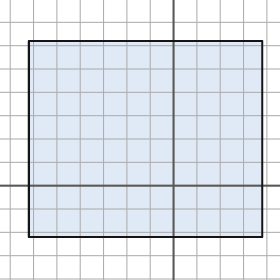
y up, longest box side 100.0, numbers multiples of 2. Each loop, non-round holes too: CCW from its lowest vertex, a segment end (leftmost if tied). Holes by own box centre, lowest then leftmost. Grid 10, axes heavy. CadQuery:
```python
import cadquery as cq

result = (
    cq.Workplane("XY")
    .moveTo(-62.0, -22.0)
    .lineTo(38.0, -22.0)
    .lineTo(38.0, 62.0)
    .lineTo(-62.0, 62.0)
    .close()
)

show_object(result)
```